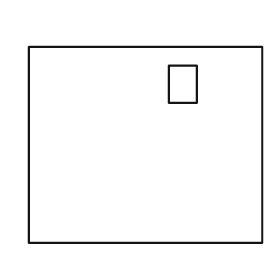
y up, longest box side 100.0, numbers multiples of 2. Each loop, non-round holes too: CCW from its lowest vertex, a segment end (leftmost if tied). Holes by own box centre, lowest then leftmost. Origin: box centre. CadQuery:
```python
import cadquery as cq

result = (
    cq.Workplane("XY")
    .moveTo(-50.0, -42.0)
    .lineTo(50.0, -42.0)
    .lineTo(50.0, 42.0)
    .lineTo(-50.0, 42.0)
    .close()
    .moveTo(10.0, 18.0)
    .lineTo(22.0, 18.0)
    .lineTo(22.0, 34.0)
    .lineTo(10.0, 34.0)
    .close()
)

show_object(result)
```